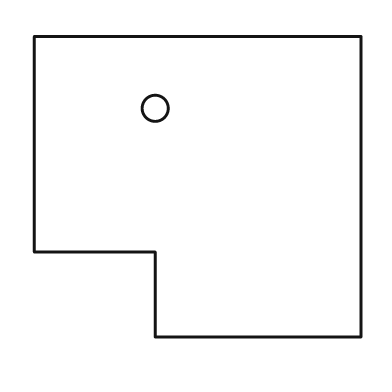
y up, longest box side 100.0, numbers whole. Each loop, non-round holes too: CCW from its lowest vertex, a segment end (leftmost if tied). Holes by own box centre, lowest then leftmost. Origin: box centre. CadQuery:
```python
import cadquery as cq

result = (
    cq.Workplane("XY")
    .moveTo(-13.0, -46.0)
    .lineTo(50.0, -46.0)
    .lineTo(50.0, 46.0)
    .lineTo(-50.0, 46.0)
    .lineTo(-50.0, -20.0)
    .lineTo(-13.0, -20.0)
    .close()
    .moveTo(-13.0, 24.0)
    .circle(4.0)
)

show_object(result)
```